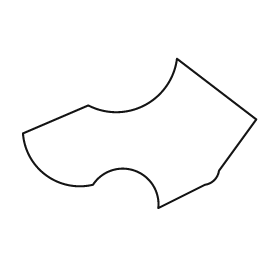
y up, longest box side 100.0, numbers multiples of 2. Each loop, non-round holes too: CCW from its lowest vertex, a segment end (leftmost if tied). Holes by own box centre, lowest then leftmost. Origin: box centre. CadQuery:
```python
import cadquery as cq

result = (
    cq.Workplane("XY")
    .moveTo(8.0, -32.0)
    .lineTo(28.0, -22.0)
    .threePointArc((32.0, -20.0), (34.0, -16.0))
    .lineTo(50.0, 6.0)
    .lineTo(16.0, 32.0)
    .threePointArc((2.0, 12.0), (-22.0, 12.0))
    .lineTo(-50.0, 0.0)
    .threePointArc((-40.0, -18.0), (-20.0, -22.0))
    .threePointArc((-2.0, -16.0), (8.0, -32.0))
    .close()
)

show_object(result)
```